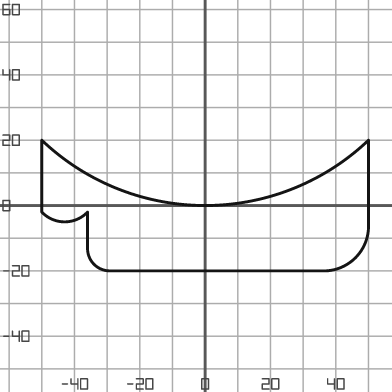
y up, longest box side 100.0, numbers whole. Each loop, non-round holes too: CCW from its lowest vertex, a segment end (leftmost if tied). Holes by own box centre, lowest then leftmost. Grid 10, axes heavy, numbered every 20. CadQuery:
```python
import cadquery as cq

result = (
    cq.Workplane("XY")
    .moveTo(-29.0, -20.0)
    .lineTo(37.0, -20.0)
    .threePointArc((46.0, -16.0), (50.0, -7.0))
    .lineTo(50.0, 20.0)
    .threePointArc((0.0, 0.0), (-50.0, 20.0))
    .lineTo(-50.0, -2.0)
    .threePointArc((-43.0, -5.0), (-36.0, -2.0))
    .lineTo(-36.0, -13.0)
    .threePointArc((-34.0, -18.0), (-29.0, -20.0))
    .close()
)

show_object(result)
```